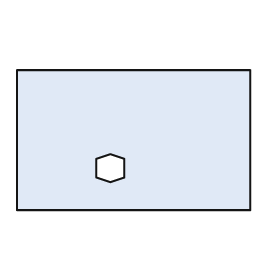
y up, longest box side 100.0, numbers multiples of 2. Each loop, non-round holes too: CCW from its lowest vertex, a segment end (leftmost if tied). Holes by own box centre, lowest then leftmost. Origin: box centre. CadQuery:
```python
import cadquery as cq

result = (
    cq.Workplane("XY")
    .moveTo(-50.0, -30.0)
    .lineTo(50.0, -30.0)
    .lineTo(50.0, 30.0)
    .lineTo(-50.0, 30.0)
    .close()
    .moveTo(-10.0, -18.0)
    .lineTo(-4.0, -16.0)
    .lineTo(-4.0, -8.0)
    .lineTo(-10.0, -6.0)
    .lineTo(-16.0, -8.0)
    .lineTo(-16.0, -16.0)
    .close()
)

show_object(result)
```